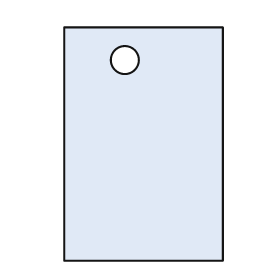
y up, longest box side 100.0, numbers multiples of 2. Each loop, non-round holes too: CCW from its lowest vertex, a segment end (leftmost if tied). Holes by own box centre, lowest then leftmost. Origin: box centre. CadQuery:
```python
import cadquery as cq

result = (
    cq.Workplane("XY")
    .moveTo(-34.0, -50.0)
    .lineTo(34.0, -50.0)
    .lineTo(34.0, 50.0)
    .lineTo(-34.0, 50.0)
    .close()
    .moveTo(-8.0, 36.0)
    .circle(6.0)
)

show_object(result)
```